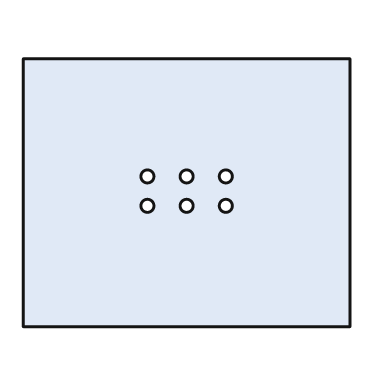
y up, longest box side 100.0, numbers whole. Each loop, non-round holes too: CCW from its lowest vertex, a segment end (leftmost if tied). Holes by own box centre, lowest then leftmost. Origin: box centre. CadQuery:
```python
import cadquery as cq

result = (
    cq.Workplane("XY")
    .moveTo(-50.0, -41.0)
    .lineTo(50.0, -41.0)
    .lineTo(50.0, 41.0)
    .lineTo(-50.0, 41.0)
    .close()
    .moveTo(-12.0, -4.0)
    .circle(2.0)
    .moveTo(0.0, -4.0)
    .circle(2.0)
    .moveTo(12.0, -4.0)
    .circle(2.0)
    .moveTo(-12.0, 5.0)
    .circle(2.0)
    .moveTo(0.0, 5.0)
    .circle(2.0)
    .moveTo(12.0, 5.0)
    .circle(2.0)
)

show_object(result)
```